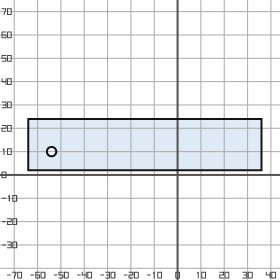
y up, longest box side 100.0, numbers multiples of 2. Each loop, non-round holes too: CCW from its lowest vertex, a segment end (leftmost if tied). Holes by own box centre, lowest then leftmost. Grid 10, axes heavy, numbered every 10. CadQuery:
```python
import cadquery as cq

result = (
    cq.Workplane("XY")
    .moveTo(-64.0, 2.0)
    .lineTo(36.0, 2.0)
    .lineTo(36.0, 24.0)
    .lineTo(-64.0, 24.0)
    .close()
    .moveTo(-54.0, 10.0)
    .circle(2.0)
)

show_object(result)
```